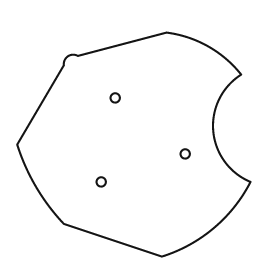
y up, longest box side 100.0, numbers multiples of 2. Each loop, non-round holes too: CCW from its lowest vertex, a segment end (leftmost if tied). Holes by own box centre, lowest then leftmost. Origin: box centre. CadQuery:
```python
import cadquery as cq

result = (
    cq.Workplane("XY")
    .moveTo(12.0, -48.0)
    .threePointArc((34.0, -36.0), (50.0, -16.0))
    .threePointArc((34.0, 6.0), (46.0, 30.0))
    .threePointArc((32.0, 42.0), (14.0, 48.0))
    .lineTo(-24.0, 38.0)
    .threePointArc((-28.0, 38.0), (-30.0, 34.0))
    .lineTo(-50.0, 0.0)
    .threePointArc((-42.0, -18.0), (-30.0, -34.0))
    .close()
    .moveTo(-14.0, -16.0)
    .circle(2.0)
    .moveTo(22.0, -4.0)
    .circle(2.0)
    .moveTo(-8.0, 20.0)
    .circle(2.0)
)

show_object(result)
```